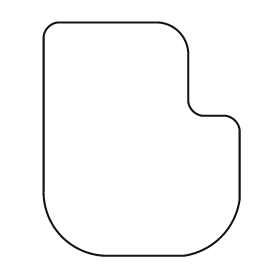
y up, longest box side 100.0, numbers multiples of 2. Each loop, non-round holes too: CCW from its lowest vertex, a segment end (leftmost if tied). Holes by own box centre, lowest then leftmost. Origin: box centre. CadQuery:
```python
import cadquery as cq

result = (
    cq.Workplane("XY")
    .moveTo(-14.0, -50.0)
    .lineTo(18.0, -50.0)
    .threePointArc((34.0, -42.0), (42.0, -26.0))
    .lineTo(42.0, 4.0)
    .threePointArc((40.0, 8.0), (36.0, 10.0))
    .lineTo(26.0, 10.0)
    .threePointArc((22.0, 12.0), (20.0, 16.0))
    .lineTo(20.0, 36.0)
    .threePointArc((16.0, 46.0), (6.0, 50.0))
    .lineTo(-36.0, 50.0)
    .threePointArc((-40.0, 48.0), (-42.0, 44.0))
    .lineTo(-42.0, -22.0)
    .threePointArc((-34.0, -42.0), (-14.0, -50.0))
    .close()
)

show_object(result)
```